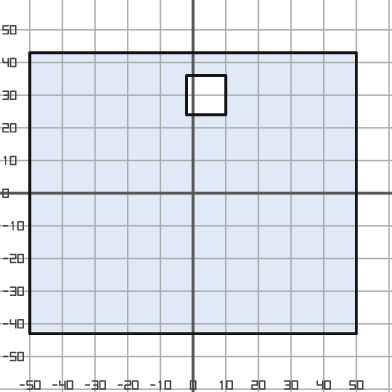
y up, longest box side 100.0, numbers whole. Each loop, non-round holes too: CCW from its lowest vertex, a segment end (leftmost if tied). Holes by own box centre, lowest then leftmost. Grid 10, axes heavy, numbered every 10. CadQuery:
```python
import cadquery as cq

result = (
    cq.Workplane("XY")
    .moveTo(-50.0, -43.0)
    .lineTo(50.0, -43.0)
    .lineTo(50.0, 43.0)
    .lineTo(-50.0, 43.0)
    .close()
    .moveTo(-2.0, 24.0)
    .lineTo(10.0, 24.0)
    .lineTo(10.0, 36.0)
    .lineTo(-2.0, 36.0)
    .close()
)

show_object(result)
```